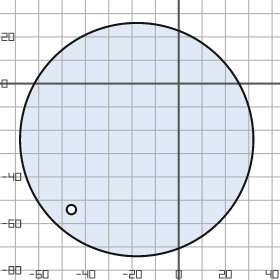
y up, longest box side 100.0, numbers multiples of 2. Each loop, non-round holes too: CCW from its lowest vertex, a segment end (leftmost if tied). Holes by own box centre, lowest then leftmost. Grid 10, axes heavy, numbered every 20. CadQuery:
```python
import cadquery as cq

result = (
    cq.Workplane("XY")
    .moveTo(-18.0, -24.0)
    .circle(50.0)
    .moveTo(-46.0, -54.0)
    .circle(2.0)
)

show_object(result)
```